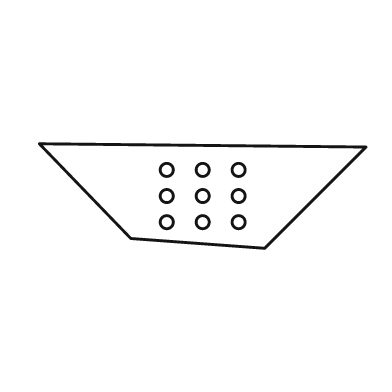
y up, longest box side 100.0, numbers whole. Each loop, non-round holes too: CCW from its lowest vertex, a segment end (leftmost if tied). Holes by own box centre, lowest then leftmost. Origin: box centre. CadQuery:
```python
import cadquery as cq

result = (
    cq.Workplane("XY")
    .moveTo(19.0, -16.0)
    .lineTo(50.0, 15.0)
    .lineTo(-50.0, 16.0)
    .lineTo(-22.0, -13.0)
    .close()
    .moveTo(-11.0, -8.0)
    .circle(2.0)
    .moveTo(0.0, -8.0)
    .circle(2.0)
    .moveTo(11.0, -8.0)
    .circle(2.0)
    .moveTo(-11.0, 0.0)
    .circle(2.0)
    .moveTo(0.0, 0.0)
    .circle(2.0)
    .moveTo(11.0, 0.0)
    .circle(2.0)
    .moveTo(-11.0, 8.0)
    .circle(2.0)
    .moveTo(0.0, 8.0)
    .circle(2.0)
    .moveTo(11.0, 8.0)
    .circle(2.0)
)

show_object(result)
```